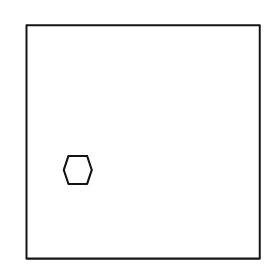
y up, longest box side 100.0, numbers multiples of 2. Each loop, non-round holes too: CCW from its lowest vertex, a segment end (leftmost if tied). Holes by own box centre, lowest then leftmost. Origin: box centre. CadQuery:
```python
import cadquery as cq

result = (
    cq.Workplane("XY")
    .moveTo(-50.0, -50.0)
    .lineTo(50.0, -50.0)
    .lineTo(50.0, 50.0)
    .lineTo(-50.0, 50.0)
    .close()
    .moveTo(-32.0, -18.0)
    .lineTo(-24.0, -18.0)
    .lineTo(-22.0, -12.0)
    .lineTo(-24.0, -6.0)
    .lineTo(-32.0, -6.0)
    .lineTo(-34.0, -12.0)
    .close()
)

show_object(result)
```